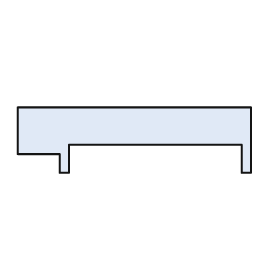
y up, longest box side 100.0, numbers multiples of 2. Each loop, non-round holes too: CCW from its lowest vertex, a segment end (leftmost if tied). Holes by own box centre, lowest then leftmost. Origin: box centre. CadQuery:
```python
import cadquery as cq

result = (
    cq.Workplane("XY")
    .moveTo(-32.0, -14.0)
    .lineTo(-28.0, -14.0)
    .lineTo(-28.0, -2.0)
    .lineTo(46.0, -2.0)
    .lineTo(46.0, -14.0)
    .lineTo(50.0, -14.0)
    .lineTo(50.0, 14.0)
    .lineTo(-50.0, 14.0)
    .lineTo(-50.0, -6.0)
    .lineTo(-32.0, -6.0)
    .close()
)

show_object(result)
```